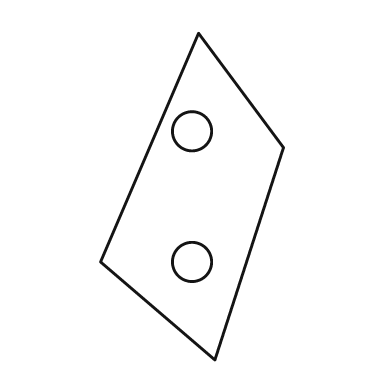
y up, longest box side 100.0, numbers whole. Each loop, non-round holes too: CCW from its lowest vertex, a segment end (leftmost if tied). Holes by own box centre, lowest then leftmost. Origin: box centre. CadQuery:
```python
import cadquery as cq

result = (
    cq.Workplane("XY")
    .moveTo(7.0, -50.0)
    .lineTo(28.0, 15.0)
    .lineTo(2.0, 50.0)
    .lineTo(-28.0, -20.0)
    .close()
    .moveTo(0.0, -20.0)
    .circle(6.0)
    .moveTo(0.0, 20.0)
    .circle(6.0)
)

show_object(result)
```